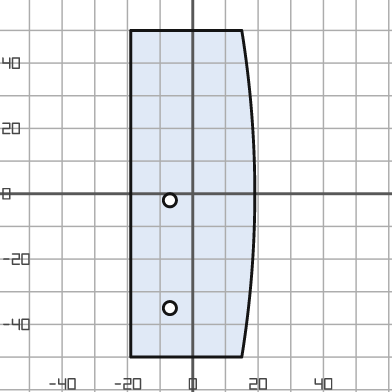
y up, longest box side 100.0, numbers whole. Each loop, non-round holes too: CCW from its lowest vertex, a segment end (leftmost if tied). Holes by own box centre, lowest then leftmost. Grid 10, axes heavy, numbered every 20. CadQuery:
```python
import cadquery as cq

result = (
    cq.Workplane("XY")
    .moveTo(-19.0, -50.0)
    .lineTo(15.0, -50.0)
    .threePointArc((19.0, 0.0), (15.0, 50.0))
    .lineTo(-19.0, 50.0)
    .close()
    .moveTo(-7.0, -35.0)
    .circle(2.0)
    .moveTo(-7.0, -2.0)
    .circle(2.0)
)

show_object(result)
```